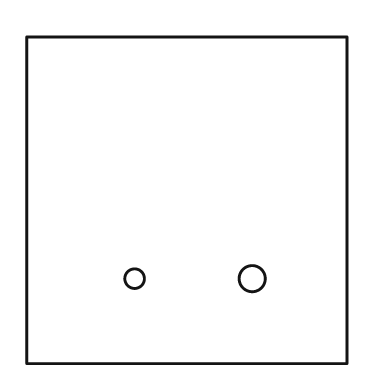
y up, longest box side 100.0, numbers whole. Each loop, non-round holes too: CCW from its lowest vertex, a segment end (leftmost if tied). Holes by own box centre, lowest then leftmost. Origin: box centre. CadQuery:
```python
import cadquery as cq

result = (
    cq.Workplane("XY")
    .moveTo(-49.0, -50.0)
    .lineTo(49.0, -50.0)
    .lineTo(49.0, 50.0)
    .lineTo(-49.0, 50.0)
    .close()
    .moveTo(-16.0, -24.0)
    .circle(3.0)
    .moveTo(20.0, -24.0)
    .circle(4.0)
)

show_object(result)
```